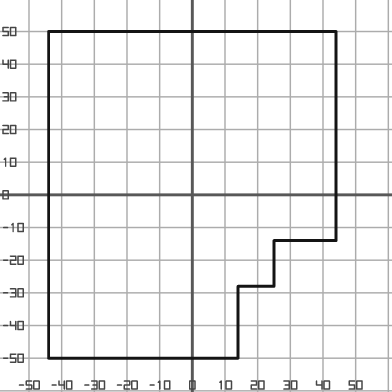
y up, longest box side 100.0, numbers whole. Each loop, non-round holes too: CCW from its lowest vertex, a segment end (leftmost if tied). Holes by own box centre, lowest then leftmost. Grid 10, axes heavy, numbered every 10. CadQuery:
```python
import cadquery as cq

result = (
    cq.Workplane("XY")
    .moveTo(-44.0, -50.0)
    .lineTo(14.0, -50.0)
    .lineTo(14.0, -28.0)
    .lineTo(25.0, -28.0)
    .lineTo(25.0, -14.0)
    .lineTo(44.0, -14.0)
    .lineTo(44.0, 50.0)
    .lineTo(-44.0, 50.0)
    .close()
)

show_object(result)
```